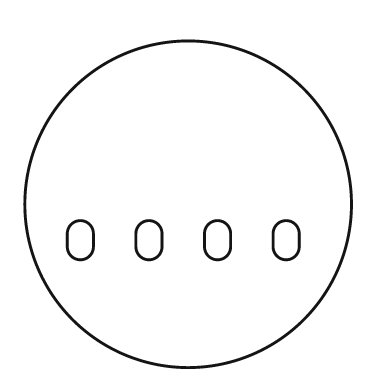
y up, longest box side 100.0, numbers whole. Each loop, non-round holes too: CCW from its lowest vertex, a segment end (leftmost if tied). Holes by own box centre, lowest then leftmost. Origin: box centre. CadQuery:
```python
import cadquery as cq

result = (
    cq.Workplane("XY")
    .moveTo(0.0, 0.0)
    .circle(50.0)
    .moveTo(-37.0, -13.0)
    .threePointArc((-33.0, -17.0), (-29.0, -13.0))
    .lineTo(-29.0, -9.0)
    .threePointArc((-33.0, -5.0), (-37.0, -9.0))
    .close()
    .moveTo(-16.0, -13.0)
    .threePointArc((-12.0, -17.0), (-8.0, -13.0))
    .lineTo(-8.0, -9.0)
    .threePointArc((-12.0, -5.0), (-16.0, -9.0))
    .close()
    .moveTo(5.0, -13.0)
    .threePointArc((9.0, -17.0), (13.0, -13.0))
    .lineTo(13.0, -9.0)
    .threePointArc((9.0, -5.0), (5.0, -9.0))
    .close()
    .moveTo(26.0, -13.0)
    .threePointArc((30.0, -17.0), (34.0, -13.0))
    .lineTo(34.0, -9.0)
    .threePointArc((30.0, -5.0), (26.0, -9.0))
    .close()
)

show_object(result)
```